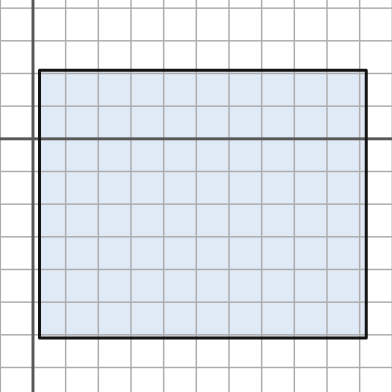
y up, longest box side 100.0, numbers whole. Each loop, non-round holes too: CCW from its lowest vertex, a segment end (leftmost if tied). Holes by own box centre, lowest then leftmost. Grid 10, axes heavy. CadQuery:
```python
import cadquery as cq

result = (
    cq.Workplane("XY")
    .moveTo(2.0, -61.0)
    .lineTo(102.0, -61.0)
    .lineTo(102.0, 21.0)
    .lineTo(2.0, 21.0)
    .close()
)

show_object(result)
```